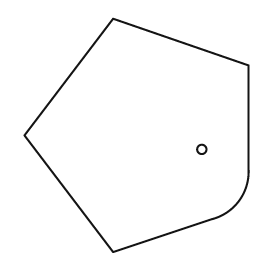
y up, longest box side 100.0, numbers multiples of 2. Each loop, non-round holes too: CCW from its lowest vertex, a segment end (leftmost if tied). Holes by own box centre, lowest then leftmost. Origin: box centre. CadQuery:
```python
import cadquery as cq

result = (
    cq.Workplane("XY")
    .moveTo(-10.0, -50.0)
    .lineTo(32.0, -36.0)
    .threePointArc((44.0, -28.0), (48.0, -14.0))
    .lineTo(48.0, 30.0)
    .lineTo(-10.0, 50.0)
    .lineTo(-48.0, 0.0)
    .close()
    .moveTo(28.0, -6.0)
    .circle(2.0)
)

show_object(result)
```